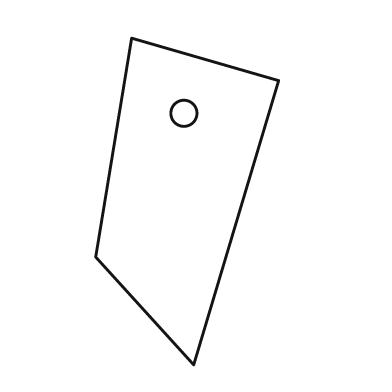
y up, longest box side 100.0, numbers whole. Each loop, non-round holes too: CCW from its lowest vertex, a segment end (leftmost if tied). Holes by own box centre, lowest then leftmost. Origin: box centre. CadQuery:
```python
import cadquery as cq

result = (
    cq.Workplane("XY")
    .moveTo(2.0, -50.0)
    .lineTo(28.0, 37.0)
    .lineTo(-17.0, 50.0)
    .lineTo(-28.0, -17.0)
    .close()
    .moveTo(-1.0, 27.0)
    .circle(4.0)
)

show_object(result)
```